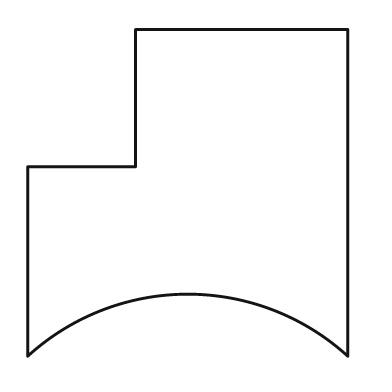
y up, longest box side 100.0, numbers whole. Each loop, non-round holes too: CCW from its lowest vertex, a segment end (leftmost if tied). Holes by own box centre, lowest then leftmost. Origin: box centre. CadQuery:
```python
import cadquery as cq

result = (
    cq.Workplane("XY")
    .moveTo(-49.0, -50.0)
    .threePointArc((0.0, -31.0), (49.0, -50.0))
    .lineTo(49.0, 50.0)
    .lineTo(-16.0, 50.0)
    .lineTo(-16.0, 8.0)
    .lineTo(-49.0, 8.0)
    .close()
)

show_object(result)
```